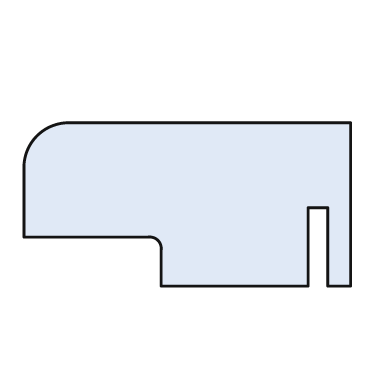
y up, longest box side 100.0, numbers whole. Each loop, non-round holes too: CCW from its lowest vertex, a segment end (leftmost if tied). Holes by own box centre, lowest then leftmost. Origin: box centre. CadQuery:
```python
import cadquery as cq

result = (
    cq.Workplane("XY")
    .moveTo(-8.0, -25.0)
    .lineTo(37.0, -25.0)
    .lineTo(37.0, -1.0)
    .lineTo(43.0, -1.0)
    .lineTo(43.0, -25.0)
    .lineTo(50.0, -25.0)
    .lineTo(50.0, 25.0)
    .lineTo(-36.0, 25.0)
    .threePointArc((-46.0, 21.0), (-50.0, 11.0))
    .lineTo(-50.0, -10.0)
    .lineTo(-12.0, -10.0)
    .threePointArc((-9.0, -11.0), (-8.0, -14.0))
    .close()
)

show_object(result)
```